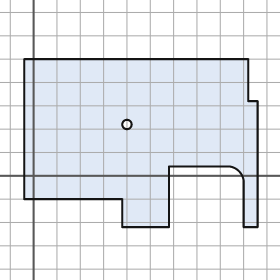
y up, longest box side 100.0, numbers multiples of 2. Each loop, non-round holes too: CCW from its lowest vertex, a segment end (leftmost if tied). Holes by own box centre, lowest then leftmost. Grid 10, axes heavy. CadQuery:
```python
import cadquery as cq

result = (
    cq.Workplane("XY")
    .moveTo(38.0, -22.0)
    .lineTo(58.0, -22.0)
    .lineTo(58.0, 4.0)
    .lineTo(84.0, 4.0)
    .threePointArc((88.0, 2.0), (90.0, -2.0))
    .lineTo(90.0, -22.0)
    .lineTo(96.0, -22.0)
    .lineTo(96.0, 32.0)
    .lineTo(92.0, 32.0)
    .lineTo(92.0, 50.0)
    .lineTo(-4.0, 50.0)
    .lineTo(-4.0, -10.0)
    .lineTo(38.0, -10.0)
    .close()
    .moveTo(40.0, 22.0)
    .circle(2.0)
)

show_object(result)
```